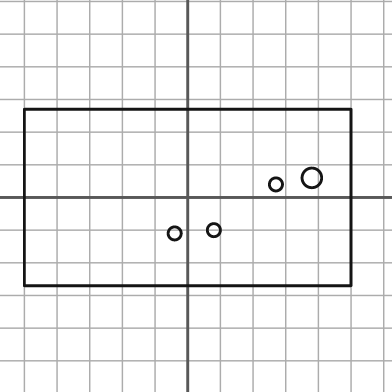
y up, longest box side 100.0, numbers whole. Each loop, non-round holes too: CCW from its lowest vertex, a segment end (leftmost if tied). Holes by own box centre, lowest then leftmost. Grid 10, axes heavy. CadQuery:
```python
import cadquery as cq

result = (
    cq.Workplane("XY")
    .moveTo(-50.0, -27.0)
    .lineTo(50.0, -27.0)
    .lineTo(50.0, 27.0)
    .lineTo(-50.0, 27.0)
    .close()
    .moveTo(-4.0, -11.0)
    .circle(2.0)
    .moveTo(8.0, -10.0)
    .circle(2.0)
    .moveTo(27.0, 4.0)
    .circle(2.0)
    .moveTo(38.0, 6.0)
    .circle(3.0)
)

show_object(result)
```